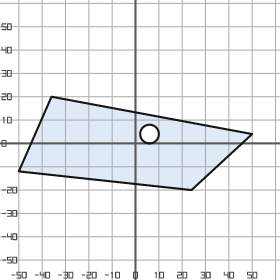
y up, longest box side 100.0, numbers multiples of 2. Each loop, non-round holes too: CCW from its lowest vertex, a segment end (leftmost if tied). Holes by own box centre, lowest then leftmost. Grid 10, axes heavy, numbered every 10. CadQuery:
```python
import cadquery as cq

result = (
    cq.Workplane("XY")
    .moveTo(24.0, -20.0)
    .lineTo(50.0, 4.0)
    .lineTo(-36.0, 20.0)
    .lineTo(-50.0, -12.0)
    .close()
    .moveTo(6.0, 4.0)
    .circle(4.0)
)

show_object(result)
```